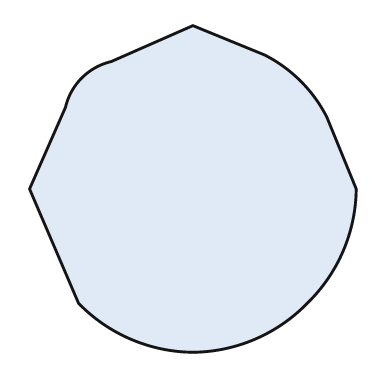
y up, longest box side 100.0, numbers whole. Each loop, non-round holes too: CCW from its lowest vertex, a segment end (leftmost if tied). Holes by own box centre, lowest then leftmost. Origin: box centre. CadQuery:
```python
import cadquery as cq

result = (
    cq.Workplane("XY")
    .moveTo(0.0, -50.0)
    .threePointArc((19.0, -46.0), (35.0, -35.0))
    .threePointArc((46.0, -19.0), (50.0, 0.0))
    .lineTo(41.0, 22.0)
    .threePointArc((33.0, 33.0), (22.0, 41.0))
    .lineTo(0.0, 50.0)
    .lineTo(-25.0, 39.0)
    .threePointArc((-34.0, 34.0), (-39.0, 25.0))
    .lineTo(-50.0, 0.0)
    .lineTo(-35.0, -35.0)
    .threePointArc((-19.0, -46.0), (0.0, -50.0))
    .close()
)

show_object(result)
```